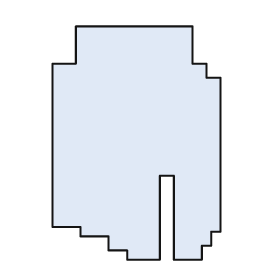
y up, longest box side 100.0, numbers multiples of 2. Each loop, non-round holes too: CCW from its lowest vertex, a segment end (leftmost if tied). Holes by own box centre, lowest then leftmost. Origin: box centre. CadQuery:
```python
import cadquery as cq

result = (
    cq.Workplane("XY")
    .moveTo(-4.0, -50.0)
    .lineTo(10.0, -50.0)
    .lineTo(10.0, -14.0)
    .lineTo(16.0, -14.0)
    .lineTo(16.0, -50.0)
    .lineTo(28.0, -50.0)
    .lineTo(28.0, -44.0)
    .lineTo(32.0, -44.0)
    .lineTo(32.0, -38.0)
    .lineTo(36.0, -38.0)
    .lineTo(36.0, 28.0)
    .lineTo(30.0, 28.0)
    .lineTo(30.0, 34.0)
    .lineTo(24.0, 34.0)
    .lineTo(24.0, 50.0)
    .lineTo(-26.0, 50.0)
    .lineTo(-26.0, 34.0)
    .lineTo(-36.0, 34.0)
    .lineTo(-36.0, -36.0)
    .lineTo(-24.0, -36.0)
    .lineTo(-24.0, -40.0)
    .lineTo(-12.0, -40.0)
    .lineTo(-12.0, -46.0)
    .lineTo(-4.0, -46.0)
    .close()
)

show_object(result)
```